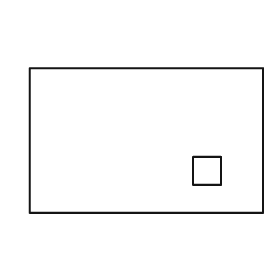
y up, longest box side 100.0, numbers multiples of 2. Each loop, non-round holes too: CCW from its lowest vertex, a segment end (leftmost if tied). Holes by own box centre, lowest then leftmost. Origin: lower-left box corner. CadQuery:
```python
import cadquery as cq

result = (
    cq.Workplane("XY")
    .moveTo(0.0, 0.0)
    .lineTo(100.0, 0.0)
    .lineTo(100.0, 62.0)
    .lineTo(0.0, 62.0)
    .close()
    .moveTo(70.0, 12.0)
    .lineTo(82.0, 12.0)
    .lineTo(82.0, 24.0)
    .lineTo(70.0, 24.0)
    .close()
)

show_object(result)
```